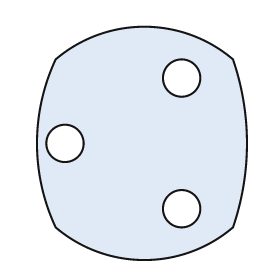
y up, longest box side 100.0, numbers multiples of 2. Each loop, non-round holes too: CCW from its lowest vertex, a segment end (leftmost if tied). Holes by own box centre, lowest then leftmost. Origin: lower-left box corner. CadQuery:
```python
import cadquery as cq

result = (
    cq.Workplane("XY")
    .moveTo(8.0, 14.0)
    .threePointArc((46.0, 0.0), (84.0, 14.0))
    .threePointArc((90.0, 50.0), (84.0, 86.0))
    .threePointArc((46.0, 100.0), (8.0, 86.0))
    .threePointArc((0.0, 50.0), (8.0, 14.0))
    .close()
    .moveTo(62.0, 22.0)
    .circle(8.0)
    .moveTo(12.0, 50.0)
    .circle(8.0)
    .moveTo(62.0, 78.0)
    .circle(8.0)
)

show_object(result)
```